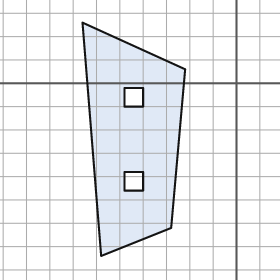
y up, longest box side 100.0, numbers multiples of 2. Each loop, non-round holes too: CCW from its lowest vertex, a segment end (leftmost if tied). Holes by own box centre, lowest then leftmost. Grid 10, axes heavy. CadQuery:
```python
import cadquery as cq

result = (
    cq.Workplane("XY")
    .moveTo(-58.0, -74.0)
    .lineTo(-28.0, -62.0)
    .lineTo(-22.0, 6.0)
    .lineTo(-66.0, 26.0)
    .close()
    .moveTo(-48.0, -46.0)
    .lineTo(-40.0, -46.0)
    .lineTo(-40.0, -38.0)
    .lineTo(-48.0, -38.0)
    .close()
    .moveTo(-48.0, -10.0)
    .lineTo(-40.0, -10.0)
    .lineTo(-40.0, -2.0)
    .lineTo(-48.0, -2.0)
    .close()
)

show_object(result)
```